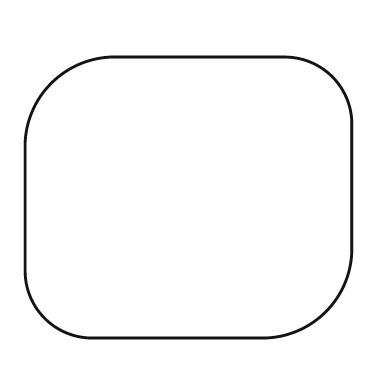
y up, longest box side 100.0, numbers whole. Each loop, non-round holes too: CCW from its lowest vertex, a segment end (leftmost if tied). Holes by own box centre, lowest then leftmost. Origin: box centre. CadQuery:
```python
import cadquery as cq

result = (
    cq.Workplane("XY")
    .moveTo(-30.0, -43.0)
    .lineTo(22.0, -43.0)
    .threePointArc((42.0, -35.0), (50.0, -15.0))
    .lineTo(50.0, 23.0)
    .threePointArc((44.0, 37.0), (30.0, 43.0))
    .lineTo(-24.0, 43.0)
    .threePointArc((-42.0, 35.0), (-50.0, 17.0))
    .lineTo(-50.0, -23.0)
    .threePointArc((-44.0, -37.0), (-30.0, -43.0))
    .close()
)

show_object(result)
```